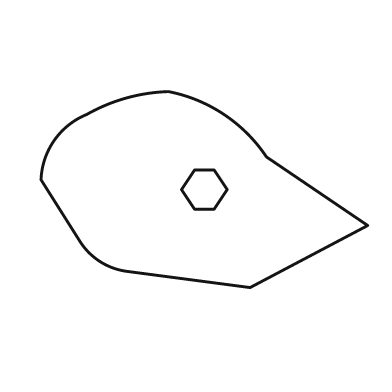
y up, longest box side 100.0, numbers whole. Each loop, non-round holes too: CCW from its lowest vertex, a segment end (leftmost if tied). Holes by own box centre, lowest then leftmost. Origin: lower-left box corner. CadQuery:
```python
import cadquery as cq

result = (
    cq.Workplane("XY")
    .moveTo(64.0, 0.0)
    .lineTo(100.0, 19.0)
    .lineTo(69.0, 40.0)
    .threePointArc((56.0, 53.0), (39.0, 60.0))
    .threePointArc((26.0, 58.0), (14.0, 53.0))
    .threePointArc((4.0, 45.0), (0.0, 33.0))
    .lineTo(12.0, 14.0)
    .threePointArc((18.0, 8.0), (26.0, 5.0))
    .close()
    .moveTo(47.0, 24.0)
    .lineTo(53.0, 24.0)
    .lineTo(57.0, 30.0)
    .lineTo(53.0, 36.0)
    .lineTo(47.0, 36.0)
    .lineTo(43.0, 30.0)
    .close()
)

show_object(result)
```